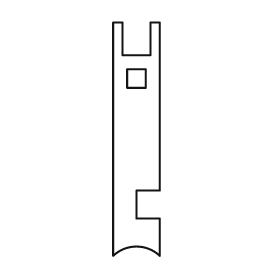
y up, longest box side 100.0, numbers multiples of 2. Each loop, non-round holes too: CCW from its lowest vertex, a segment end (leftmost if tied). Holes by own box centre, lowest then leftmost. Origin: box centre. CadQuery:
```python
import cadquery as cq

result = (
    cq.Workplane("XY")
    .moveTo(-10.0, -50.0)
    .threePointArc((0.0, -46.0), (10.0, -50.0))
    .lineTo(10.0, -34.0)
    .lineTo(0.0, -34.0)
    .lineTo(0.0, -22.0)
    .lineTo(10.0, -22.0)
    .lineTo(10.0, 50.0)
    .lineTo(6.0, 50.0)
    .lineTo(6.0, 36.0)
    .lineTo(-6.0, 36.0)
    .lineTo(-6.0, 50.0)
    .lineTo(-10.0, 50.0)
    .close()
    .moveTo(-4.0, 22.0)
    .lineTo(4.0, 22.0)
    .lineTo(4.0, 30.0)
    .lineTo(-4.0, 30.0)
    .close()
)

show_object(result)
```